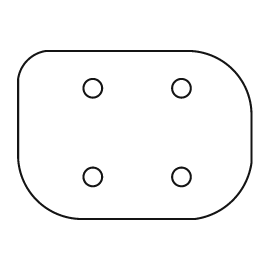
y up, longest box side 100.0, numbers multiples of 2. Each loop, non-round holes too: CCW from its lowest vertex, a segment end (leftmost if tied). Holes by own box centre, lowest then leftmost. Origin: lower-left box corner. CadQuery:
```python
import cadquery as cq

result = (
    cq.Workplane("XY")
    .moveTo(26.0, 0.0)
    .lineTo(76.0, 0.0)
    .threePointArc((92.0, 8.0), (100.0, 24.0))
    .lineTo(100.0, 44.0)
    .threePointArc((92.0, 64.0), (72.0, 72.0))
    .lineTo(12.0, 72.0)
    .threePointArc((4.0, 68.0), (0.0, 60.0))
    .lineTo(0.0, 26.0)
    .threePointArc((8.0, 8.0), (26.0, 0.0))
    .close()
    .moveTo(32.0, 18.0)
    .circle(4.0)
    .moveTo(70.0, 18.0)
    .circle(4.0)
    .moveTo(32.0, 56.0)
    .circle(4.0)
    .moveTo(70.0, 56.0)
    .circle(4.0)
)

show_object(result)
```